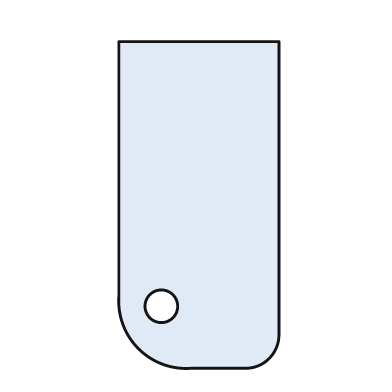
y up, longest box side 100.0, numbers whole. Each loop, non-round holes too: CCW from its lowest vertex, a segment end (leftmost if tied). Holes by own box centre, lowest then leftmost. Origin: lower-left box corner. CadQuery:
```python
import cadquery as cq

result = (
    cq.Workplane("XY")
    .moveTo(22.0, 0.0)
    .lineTo(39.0, 0.0)
    .threePointArc((46.0, 3.0), (49.0, 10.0))
    .lineTo(49.0, 100.0)
    .lineTo(0.0, 100.0)
    .lineTo(0.0, 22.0)
    .threePointArc((6.0, 6.0), (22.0, 0.0))
    .close()
    .moveTo(13.0, 19.0)
    .circle(5.0)
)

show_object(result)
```